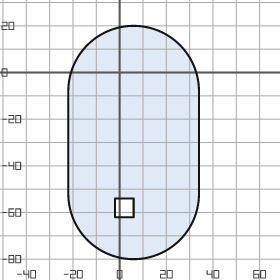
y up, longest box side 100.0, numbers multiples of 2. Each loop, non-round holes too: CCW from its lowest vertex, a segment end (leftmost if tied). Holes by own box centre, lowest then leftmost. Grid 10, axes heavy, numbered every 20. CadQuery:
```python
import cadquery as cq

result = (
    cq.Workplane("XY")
    .moveTo(-22.0, -52.0)
    .threePointArc((6.0, -80.0), (34.0, -52.0))
    .lineTo(34.0, -8.0)
    .threePointArc((6.0, 20.0), (-22.0, -8.0))
    .close()
    .moveTo(-2.0, -62.0)
    .lineTo(6.0, -62.0)
    .lineTo(6.0, -54.0)
    .lineTo(-2.0, -54.0)
    .close()
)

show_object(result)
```